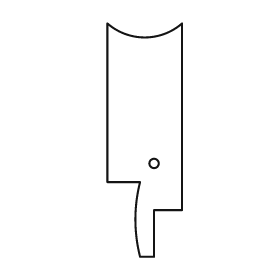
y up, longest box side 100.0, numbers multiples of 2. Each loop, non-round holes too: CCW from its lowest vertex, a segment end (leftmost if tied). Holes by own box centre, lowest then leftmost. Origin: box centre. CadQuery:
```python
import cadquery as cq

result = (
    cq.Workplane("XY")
    .moveTo(-2.0, -50.0)
    .lineTo(4.0, -50.0)
    .lineTo(4.0, -30.0)
    .lineTo(16.0, -30.0)
    .lineTo(16.0, 50.0)
    .threePointArc((0.0, 44.0), (-16.0, 50.0))
    .lineTo(-16.0, -18.0)
    .lineTo(-2.0, -18.0)
    .threePointArc((-4.0, -34.0), (-2.0, -50.0))
    .close()
    .moveTo(4.0, -10.0)
    .circle(2.0)
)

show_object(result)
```